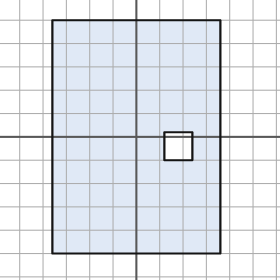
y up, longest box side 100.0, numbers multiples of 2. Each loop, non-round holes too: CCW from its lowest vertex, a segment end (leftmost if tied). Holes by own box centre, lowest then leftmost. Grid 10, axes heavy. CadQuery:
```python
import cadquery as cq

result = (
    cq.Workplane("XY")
    .moveTo(-36.0, -50.0)
    .lineTo(36.0, -50.0)
    .lineTo(36.0, 50.0)
    .lineTo(-36.0, 50.0)
    .close()
    .moveTo(12.0, -10.0)
    .lineTo(24.0, -10.0)
    .lineTo(24.0, 2.0)
    .lineTo(12.0, 2.0)
    .close()
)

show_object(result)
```